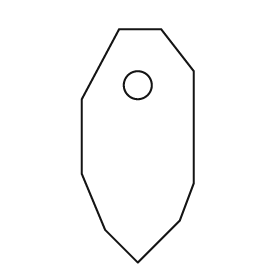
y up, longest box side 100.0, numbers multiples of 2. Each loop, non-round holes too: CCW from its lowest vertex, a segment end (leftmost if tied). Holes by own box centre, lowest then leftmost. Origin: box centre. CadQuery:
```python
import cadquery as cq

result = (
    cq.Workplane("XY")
    .moveTo(0.0, -50.0)
    .lineTo(18.0, -32.0)
    .lineTo(24.0, -16.0)
    .lineTo(24.0, 32.0)
    .lineTo(10.0, 50.0)
    .lineTo(-8.0, 50.0)
    .lineTo(-24.0, 20.0)
    .lineTo(-24.0, -12.0)
    .lineTo(-14.0, -36.0)
    .close()
    .moveTo(0.0, 26.0)
    .circle(6.0)
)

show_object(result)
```